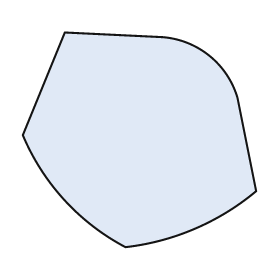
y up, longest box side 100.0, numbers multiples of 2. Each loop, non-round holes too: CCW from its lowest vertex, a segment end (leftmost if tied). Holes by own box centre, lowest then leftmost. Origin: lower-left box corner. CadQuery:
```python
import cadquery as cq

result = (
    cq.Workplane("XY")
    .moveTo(44.0, 0.0)
    .threePointArc((74.0, 8.0), (100.0, 24.0))
    .lineTo(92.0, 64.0)
    .threePointArc((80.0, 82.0), (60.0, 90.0))
    .lineTo(18.0, 92.0)
    .lineTo(0.0, 48.0)
    .threePointArc((18.0, 20.0), (44.0, 0.0))
    .close()
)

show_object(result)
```